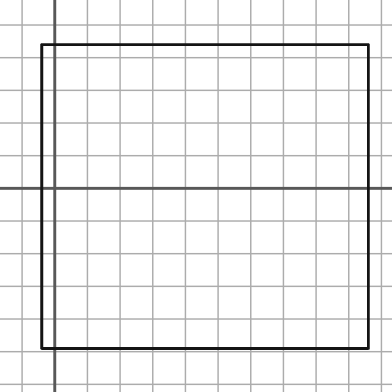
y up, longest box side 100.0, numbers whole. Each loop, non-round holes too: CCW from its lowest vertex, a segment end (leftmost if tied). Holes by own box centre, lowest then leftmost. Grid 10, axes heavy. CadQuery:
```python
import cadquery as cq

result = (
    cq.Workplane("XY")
    .moveTo(-4.0, -49.0)
    .lineTo(96.0, -49.0)
    .lineTo(96.0, 44.0)
    .lineTo(-4.0, 44.0)
    .close()
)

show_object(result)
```